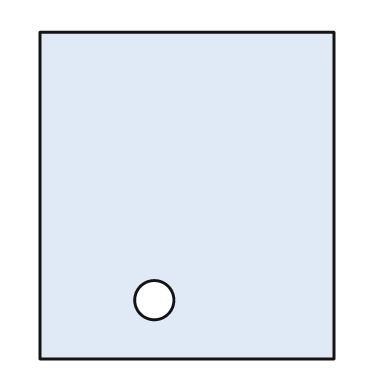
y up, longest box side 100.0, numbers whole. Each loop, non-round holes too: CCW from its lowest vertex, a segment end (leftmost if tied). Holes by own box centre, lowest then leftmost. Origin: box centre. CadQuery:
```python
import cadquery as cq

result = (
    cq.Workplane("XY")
    .moveTo(-45.0, -50.0)
    .lineTo(45.0, -50.0)
    .lineTo(45.0, 50.0)
    .lineTo(-45.0, 50.0)
    .close()
    .moveTo(-10.0, -32.0)
    .circle(6.0)
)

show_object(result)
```